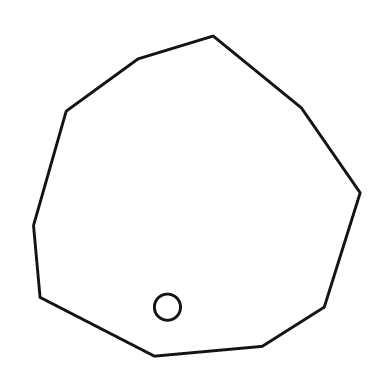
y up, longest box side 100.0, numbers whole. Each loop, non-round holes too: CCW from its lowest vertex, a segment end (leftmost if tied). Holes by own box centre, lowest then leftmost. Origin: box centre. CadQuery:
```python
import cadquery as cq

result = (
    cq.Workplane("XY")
    .moveTo(-13.0, -49.0)
    .lineTo(20.0, -46.0)
    .lineTo(39.0, -34.0)
    .lineTo(50.0, 1.0)
    .lineTo(32.0, 27.0)
    .lineTo(5.0, 49.0)
    .lineTo(-18.0, 42.0)
    .lineTo(-40.0, 26.0)
    .lineTo(-50.0, -9.0)
    .lineTo(-48.0, -31.0)
    .close()
    .moveTo(-9.0, -34.0)
    .circle(4.0)
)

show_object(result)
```